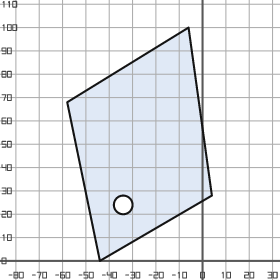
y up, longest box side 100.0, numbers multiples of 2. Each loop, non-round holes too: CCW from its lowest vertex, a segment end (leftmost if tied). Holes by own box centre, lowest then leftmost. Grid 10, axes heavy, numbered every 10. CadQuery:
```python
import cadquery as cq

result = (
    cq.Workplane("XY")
    .moveTo(-44.0, 0.0)
    .lineTo(4.0, 28.0)
    .lineTo(-6.0, 100.0)
    .lineTo(-58.0, 68.0)
    .close()
    .moveTo(-34.0, 24.0)
    .circle(4.0)
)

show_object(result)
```